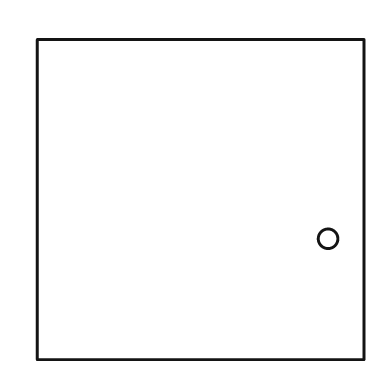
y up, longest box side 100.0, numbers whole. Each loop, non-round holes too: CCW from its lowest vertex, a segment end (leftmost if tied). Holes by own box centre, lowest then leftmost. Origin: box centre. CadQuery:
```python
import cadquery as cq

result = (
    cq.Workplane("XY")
    .moveTo(-50.0, -49.0)
    .lineTo(50.0, -49.0)
    .lineTo(50.0, 49.0)
    .lineTo(-50.0, 49.0)
    .close()
    .moveTo(39.0, -12.0)
    .circle(3.0)
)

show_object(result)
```